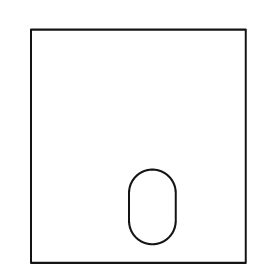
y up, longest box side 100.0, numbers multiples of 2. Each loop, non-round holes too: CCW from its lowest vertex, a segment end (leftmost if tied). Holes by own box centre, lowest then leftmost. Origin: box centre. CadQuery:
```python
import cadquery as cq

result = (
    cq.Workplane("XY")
    .moveTo(-46.0, -50.0)
    .lineTo(46.0, -50.0)
    .lineTo(46.0, 50.0)
    .lineTo(-46.0, 50.0)
    .close()
    .moveTo(-4.0, -32.0)
    .threePointArc((6.0, -42.0), (16.0, -32.0))
    .lineTo(16.0, -20.0)
    .threePointArc((6.0, -10.0), (-4.0, -20.0))
    .close()
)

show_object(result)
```